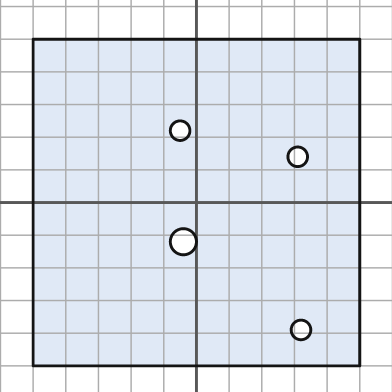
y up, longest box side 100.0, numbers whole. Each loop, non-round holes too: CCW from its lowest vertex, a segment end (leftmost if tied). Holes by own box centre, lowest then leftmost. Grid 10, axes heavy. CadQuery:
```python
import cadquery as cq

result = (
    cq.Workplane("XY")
    .moveTo(-50.0, -50.0)
    .lineTo(50.0, -50.0)
    .lineTo(50.0, 50.0)
    .lineTo(-50.0, 50.0)
    .close()
    .moveTo(32.0, -39.0)
    .circle(3.0)
    .moveTo(-4.0, -12.0)
    .circle(4.0)
    .moveTo(31.0, 14.0)
    .circle(3.0)
    .moveTo(-5.0, 22.0)
    .circle(3.0)
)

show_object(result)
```